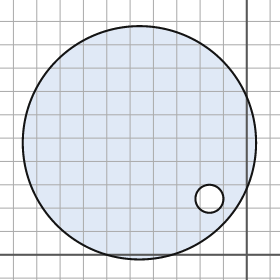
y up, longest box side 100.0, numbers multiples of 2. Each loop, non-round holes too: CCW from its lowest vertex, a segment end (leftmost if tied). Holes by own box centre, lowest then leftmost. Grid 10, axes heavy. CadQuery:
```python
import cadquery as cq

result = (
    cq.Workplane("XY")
    .moveTo(-46.0, 48.0)
    .circle(50.0)
    .moveTo(-16.0, 24.0)
    .circle(6.0)
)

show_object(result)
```